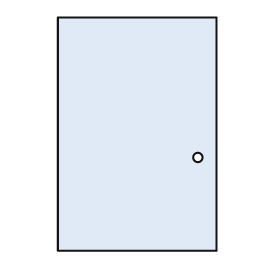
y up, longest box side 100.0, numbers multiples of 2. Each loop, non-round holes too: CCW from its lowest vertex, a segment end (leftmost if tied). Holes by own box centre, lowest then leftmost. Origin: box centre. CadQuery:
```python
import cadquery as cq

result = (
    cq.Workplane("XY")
    .moveTo(-34.0, -50.0)
    .lineTo(34.0, -50.0)
    .lineTo(34.0, 50.0)
    .lineTo(-34.0, 50.0)
    .close()
    .moveTo(26.0, -10.0)
    .circle(2.0)
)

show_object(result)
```